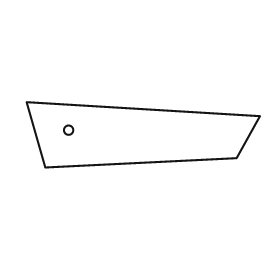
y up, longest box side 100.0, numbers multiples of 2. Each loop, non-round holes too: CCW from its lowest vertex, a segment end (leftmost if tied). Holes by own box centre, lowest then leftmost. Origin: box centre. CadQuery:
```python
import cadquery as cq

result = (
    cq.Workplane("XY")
    .moveTo(-42.0, -14.0)
    .lineTo(40.0, -10.0)
    .lineTo(50.0, 8.0)
    .lineTo(-50.0, 14.0)
    .close()
    .moveTo(-32.0, 2.0)
    .circle(2.0)
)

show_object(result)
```